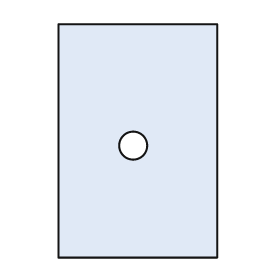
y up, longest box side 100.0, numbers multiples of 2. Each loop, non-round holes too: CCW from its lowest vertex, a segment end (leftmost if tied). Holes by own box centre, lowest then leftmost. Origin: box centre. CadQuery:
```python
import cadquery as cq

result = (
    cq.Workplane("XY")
    .moveTo(-34.0, -50.0)
    .lineTo(34.0, -50.0)
    .lineTo(34.0, 50.0)
    .lineTo(-34.0, 50.0)
    .close()
    .moveTo(-2.0, -2.0)
    .circle(6.0)
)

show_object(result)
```